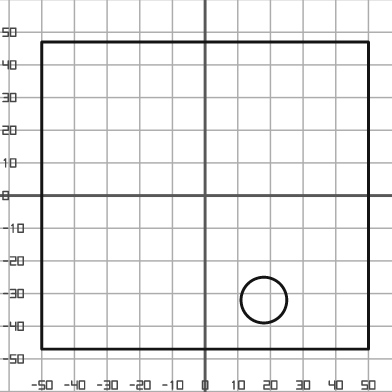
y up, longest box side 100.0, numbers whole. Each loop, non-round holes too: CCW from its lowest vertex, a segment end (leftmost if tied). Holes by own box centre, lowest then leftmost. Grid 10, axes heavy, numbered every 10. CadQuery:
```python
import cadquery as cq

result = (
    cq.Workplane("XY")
    .moveTo(-50.0, -47.0)
    .lineTo(50.0, -47.0)
    .lineTo(50.0, 47.0)
    .lineTo(-50.0, 47.0)
    .close()
    .moveTo(18.0, -32.0)
    .circle(7.0)
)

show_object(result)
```